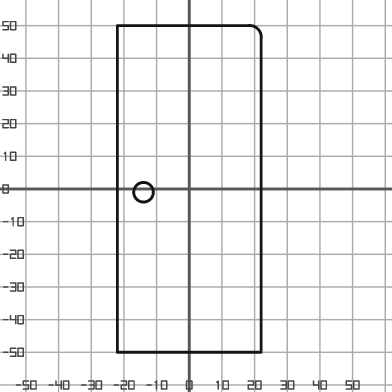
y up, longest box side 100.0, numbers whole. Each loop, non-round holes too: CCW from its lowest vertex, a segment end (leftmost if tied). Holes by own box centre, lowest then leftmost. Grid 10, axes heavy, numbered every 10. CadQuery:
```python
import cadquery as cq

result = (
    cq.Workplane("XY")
    .moveTo(-22.0, -50.0)
    .lineTo(22.0, -50.0)
    .lineTo(22.0, 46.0)
    .threePointArc((21.0, 49.0), (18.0, 50.0))
    .lineTo(-22.0, 50.0)
    .close()
    .moveTo(-14.0, -1.0)
    .circle(3.0)
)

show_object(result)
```